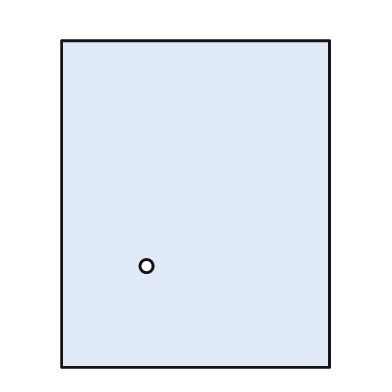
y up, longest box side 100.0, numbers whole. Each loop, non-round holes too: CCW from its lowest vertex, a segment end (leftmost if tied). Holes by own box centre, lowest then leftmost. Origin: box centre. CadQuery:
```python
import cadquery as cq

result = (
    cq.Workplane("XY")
    .moveTo(-41.0, -50.0)
    .lineTo(41.0, -50.0)
    .lineTo(41.0, 50.0)
    .lineTo(-41.0, 50.0)
    .close()
    .moveTo(-15.0, -19.0)
    .circle(2.0)
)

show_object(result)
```